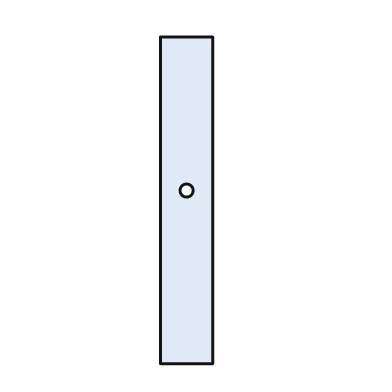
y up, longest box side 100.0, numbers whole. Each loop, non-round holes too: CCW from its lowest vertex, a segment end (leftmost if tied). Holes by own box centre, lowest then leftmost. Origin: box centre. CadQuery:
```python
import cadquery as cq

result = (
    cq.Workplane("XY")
    .moveTo(-8.0, -50.0)
    .lineTo(8.0, -50.0)
    .lineTo(8.0, 50.0)
    .lineTo(-8.0, 50.0)
    .close()
    .moveTo(0.0, 3.0)
    .circle(2.0)
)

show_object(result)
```